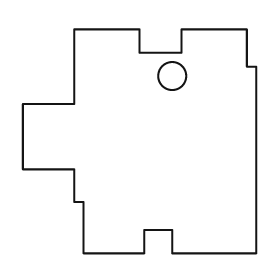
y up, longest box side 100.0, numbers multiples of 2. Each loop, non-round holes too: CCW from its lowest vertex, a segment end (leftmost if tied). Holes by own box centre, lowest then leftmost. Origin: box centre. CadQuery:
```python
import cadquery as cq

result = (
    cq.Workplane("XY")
    .moveTo(-24.0, -48.0)
    .lineTo(2.0, -48.0)
    .lineTo(2.0, -38.0)
    .lineTo(14.0, -38.0)
    .lineTo(14.0, -48.0)
    .lineTo(50.0, -48.0)
    .lineTo(50.0, 32.0)
    .lineTo(46.0, 32.0)
    .lineTo(46.0, 48.0)
    .lineTo(18.0, 48.0)
    .lineTo(18.0, 38.0)
    .lineTo(0.0, 38.0)
    .lineTo(0.0, 48.0)
    .lineTo(-28.0, 48.0)
    .lineTo(-28.0, 16.0)
    .lineTo(-50.0, 16.0)
    .lineTo(-50.0, -12.0)
    .lineTo(-28.0, -12.0)
    .lineTo(-28.0, -26.0)
    .lineTo(-24.0, -26.0)
    .close()
    .moveTo(14.0, 28.0)
    .circle(6.0)
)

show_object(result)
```